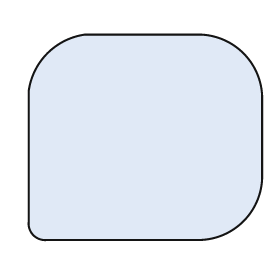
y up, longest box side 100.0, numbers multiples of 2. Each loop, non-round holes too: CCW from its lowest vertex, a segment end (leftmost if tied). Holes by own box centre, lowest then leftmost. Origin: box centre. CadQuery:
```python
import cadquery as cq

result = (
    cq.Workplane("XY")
    .moveTo(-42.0, -44.0)
    .lineTo(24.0, -44.0)
    .threePointArc((42.0, -36.0), (50.0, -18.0))
    .lineTo(50.0, 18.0)
    .threePointArc((42.0, 36.0), (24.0, 44.0))
    .lineTo(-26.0, 44.0)
    .threePointArc((-42.0, 36.0), (-50.0, 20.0))
    .lineTo(-50.0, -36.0)
    .threePointArc((-48.0, -42.0), (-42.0, -44.0))
    .close()
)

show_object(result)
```